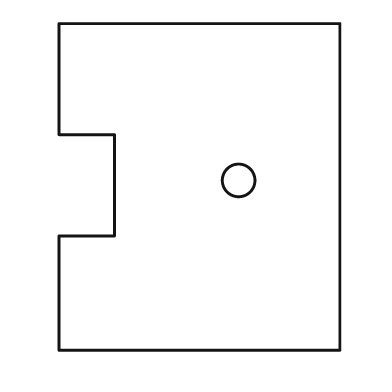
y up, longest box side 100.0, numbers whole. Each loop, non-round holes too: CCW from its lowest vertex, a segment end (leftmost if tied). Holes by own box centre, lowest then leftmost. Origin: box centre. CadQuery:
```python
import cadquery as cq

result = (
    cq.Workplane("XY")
    .moveTo(-43.0, -50.0)
    .lineTo(43.0, -50.0)
    .lineTo(43.0, 50.0)
    .lineTo(-43.0, 50.0)
    .lineTo(-43.0, 16.0)
    .lineTo(-26.0, 16.0)
    .lineTo(-26.0, -15.0)
    .lineTo(-43.0, -15.0)
    .close()
    .moveTo(12.0, 2.0)
    .circle(5.0)
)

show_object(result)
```